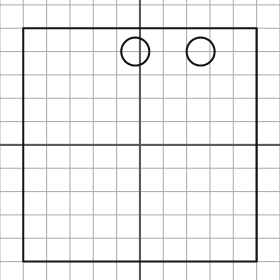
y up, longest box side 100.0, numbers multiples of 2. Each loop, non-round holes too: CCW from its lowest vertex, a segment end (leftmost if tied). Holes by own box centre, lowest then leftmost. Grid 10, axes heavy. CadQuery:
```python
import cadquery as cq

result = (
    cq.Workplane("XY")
    .moveTo(-50.0, -50.0)
    .lineTo(50.0, -50.0)
    .lineTo(50.0, 50.0)
    .lineTo(-50.0, 50.0)
    .close()
    .moveTo(-2.0, 40.0)
    .circle(6.0)
    .moveTo(26.0, 40.0)
    .circle(6.0)
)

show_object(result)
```